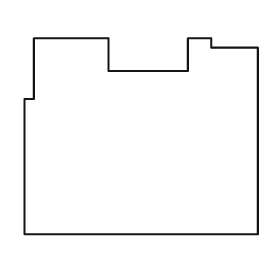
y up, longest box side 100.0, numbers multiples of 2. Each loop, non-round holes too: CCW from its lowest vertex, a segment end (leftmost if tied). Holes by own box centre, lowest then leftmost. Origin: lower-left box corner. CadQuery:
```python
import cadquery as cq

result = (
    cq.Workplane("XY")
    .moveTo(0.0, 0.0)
    .lineTo(100.0, 0.0)
    .lineTo(100.0, 80.0)
    .lineTo(80.0, 80.0)
    .lineTo(80.0, 84.0)
    .lineTo(70.0, 84.0)
    .lineTo(70.0, 70.0)
    .lineTo(36.0, 70.0)
    .lineTo(36.0, 84.0)
    .lineTo(4.0, 84.0)
    .lineTo(4.0, 58.0)
    .lineTo(0.0, 58.0)
    .close()
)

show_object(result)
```